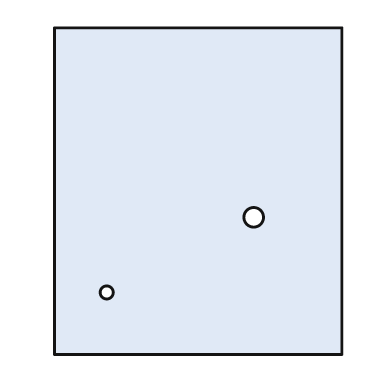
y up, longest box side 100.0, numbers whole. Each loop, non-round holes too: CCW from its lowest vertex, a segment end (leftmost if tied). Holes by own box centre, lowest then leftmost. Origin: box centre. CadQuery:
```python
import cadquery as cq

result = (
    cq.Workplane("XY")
    .moveTo(-44.0, -50.0)
    .lineTo(44.0, -50.0)
    .lineTo(44.0, 50.0)
    .lineTo(-44.0, 50.0)
    .close()
    .moveTo(-28.0, -31.0)
    .circle(2.0)
    .moveTo(17.0, -8.0)
    .circle(3.0)
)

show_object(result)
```